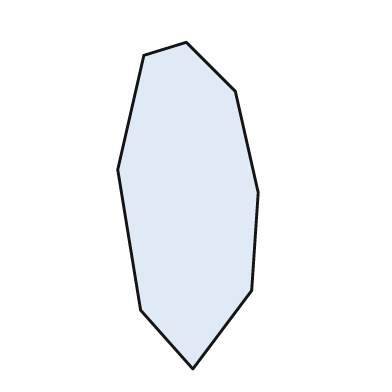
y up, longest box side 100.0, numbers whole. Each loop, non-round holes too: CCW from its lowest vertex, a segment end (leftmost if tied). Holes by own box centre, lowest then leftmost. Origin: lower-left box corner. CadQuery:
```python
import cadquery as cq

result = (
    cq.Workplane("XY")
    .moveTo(23.0, 0.0)
    .lineTo(41.0, 24.0)
    .lineTo(43.0, 54.0)
    .lineTo(36.0, 85.0)
    .lineTo(21.0, 100.0)
    .lineTo(8.0, 96.0)
    .lineTo(0.0, 61.0)
    .lineTo(7.0, 18.0)
    .close()
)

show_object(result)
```